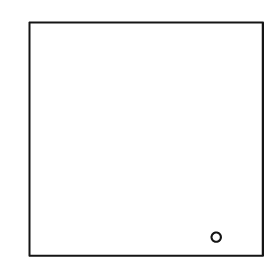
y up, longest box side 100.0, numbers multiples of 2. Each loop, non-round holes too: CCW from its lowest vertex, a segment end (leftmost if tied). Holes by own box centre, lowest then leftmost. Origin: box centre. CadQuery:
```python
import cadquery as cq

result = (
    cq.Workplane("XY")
    .moveTo(-50.0, -50.0)
    .lineTo(50.0, -50.0)
    .lineTo(50.0, 50.0)
    .lineTo(-50.0, 50.0)
    .close()
    .moveTo(30.0, -42.0)
    .circle(2.0)
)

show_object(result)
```